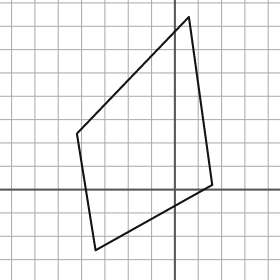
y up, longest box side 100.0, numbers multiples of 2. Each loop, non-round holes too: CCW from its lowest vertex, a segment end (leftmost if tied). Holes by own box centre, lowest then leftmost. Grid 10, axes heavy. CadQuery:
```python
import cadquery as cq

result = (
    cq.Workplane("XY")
    .moveTo(-34.0, -26.0)
    .lineTo(16.0, 2.0)
    .lineTo(6.0, 74.0)
    .lineTo(-42.0, 24.0)
    .close()
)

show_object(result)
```